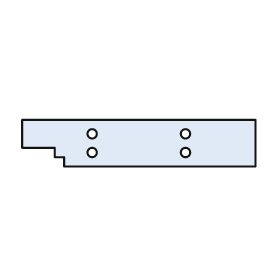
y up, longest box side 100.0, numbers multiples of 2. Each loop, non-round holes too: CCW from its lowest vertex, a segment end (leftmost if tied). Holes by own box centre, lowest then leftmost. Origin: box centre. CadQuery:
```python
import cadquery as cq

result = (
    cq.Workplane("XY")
    .moveTo(-32.0, -10.0)
    .lineTo(50.0, -10.0)
    .lineTo(50.0, 10.0)
    .lineTo(-50.0, 10.0)
    .lineTo(-50.0, -2.0)
    .lineTo(-36.0, -2.0)
    .lineTo(-36.0, -6.0)
    .lineTo(-32.0, -6.0)
    .close()
    .moveTo(-20.0, -4.0)
    .circle(2.0)
    .moveTo(20.0, -4.0)
    .circle(2.0)
    .moveTo(-20.0, 4.0)
    .circle(2.0)
    .moveTo(20.0, 4.0)
    .circle(2.0)
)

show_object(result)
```